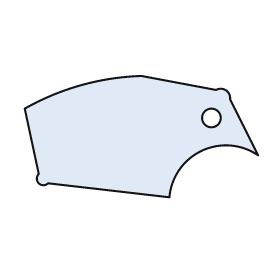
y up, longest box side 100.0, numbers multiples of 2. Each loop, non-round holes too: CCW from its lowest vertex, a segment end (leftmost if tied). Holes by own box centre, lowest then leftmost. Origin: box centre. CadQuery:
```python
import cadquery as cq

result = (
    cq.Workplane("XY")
    .moveTo(12.0, -26.0)
    .threePointArc((26.0, -6.0), (50.0, -8.0))
    .lineTo(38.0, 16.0)
    .threePointArc((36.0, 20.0), (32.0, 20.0))
    .lineTo(0.0, 26.0)
    .threePointArc((-26.0, 22.0), (-50.0, 12.0))
    .lineTo(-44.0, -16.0)
    .threePointArc((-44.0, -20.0), (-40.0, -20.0))
    .close()
    .moveTo(30.0, 8.0)
    .circle(4.0)
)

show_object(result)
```